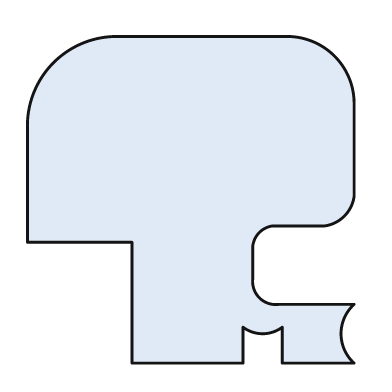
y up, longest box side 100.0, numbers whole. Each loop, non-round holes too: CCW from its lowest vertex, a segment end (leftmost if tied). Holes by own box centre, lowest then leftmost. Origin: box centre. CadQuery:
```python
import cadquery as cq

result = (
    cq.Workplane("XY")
    .moveTo(-18.0, -50.0)
    .lineTo(16.0, -50.0)
    .lineTo(16.0, -39.0)
    .threePointArc((22.0, -41.0), (28.0, -39.0))
    .lineTo(28.0, -50.0)
    .lineTo(50.0, -50.0)
    .threePointArc((46.0, -41.0), (50.0, -32.0))
    .lineTo(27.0, -32.0)
    .threePointArc((21.0, -30.0), (19.0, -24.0))
    .lineTo(19.0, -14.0)
    .threePointArc((21.0, -10.0), (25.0, -8.0))
    .lineTo(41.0, -8.0)
    .threePointArc((47.0, -5.0), (50.0, 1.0))
    .lineTo(50.0, 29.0)
    .threePointArc((44.0, 44.0), (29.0, 50.0))
    .lineTo(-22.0, 50.0)
    .threePointArc((-42.0, 42.0), (-50.0, 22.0))
    .lineTo(-50.0, -13.0)
    .lineTo(-18.0, -13.0)
    .close()
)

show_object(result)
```